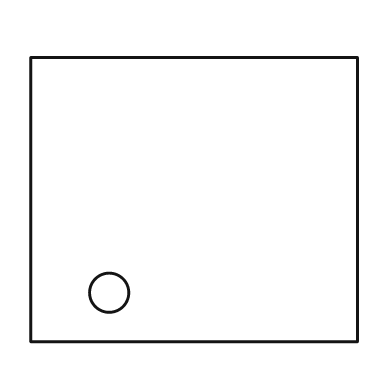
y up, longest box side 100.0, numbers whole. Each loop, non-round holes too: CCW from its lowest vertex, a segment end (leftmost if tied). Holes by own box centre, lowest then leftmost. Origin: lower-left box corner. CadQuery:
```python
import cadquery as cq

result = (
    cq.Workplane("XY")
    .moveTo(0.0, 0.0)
    .lineTo(100.0, 0.0)
    .lineTo(100.0, 87.0)
    .lineTo(0.0, 87.0)
    .close()
    .moveTo(24.0, 15.0)
    .circle(6.0)
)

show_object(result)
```